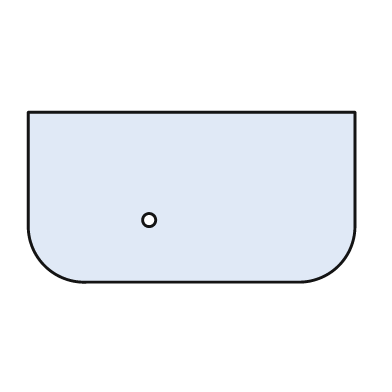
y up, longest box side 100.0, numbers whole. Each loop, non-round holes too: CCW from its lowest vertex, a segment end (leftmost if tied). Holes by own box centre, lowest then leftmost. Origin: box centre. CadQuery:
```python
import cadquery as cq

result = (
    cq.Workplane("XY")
    .moveTo(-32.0, -26.0)
    .lineTo(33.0, -26.0)
    .threePointArc((45.0, -21.0), (50.0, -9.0))
    .lineTo(50.0, 26.0)
    .lineTo(-50.0, 26.0)
    .lineTo(-50.0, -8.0)
    .threePointArc((-45.0, -21.0), (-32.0, -26.0))
    .close()
    .moveTo(-13.0, -7.0)
    .circle(2.0)
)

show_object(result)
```